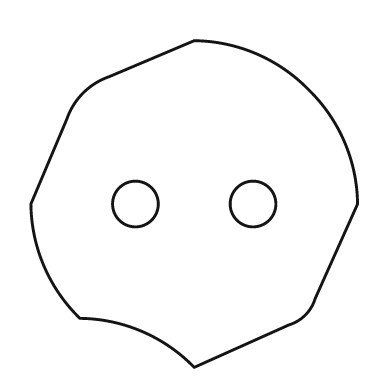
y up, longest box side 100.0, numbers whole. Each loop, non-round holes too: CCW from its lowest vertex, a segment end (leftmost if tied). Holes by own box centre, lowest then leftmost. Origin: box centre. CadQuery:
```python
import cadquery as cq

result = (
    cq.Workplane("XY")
    .moveTo(0.0, -50.0)
    .lineTo(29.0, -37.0)
    .threePointArc((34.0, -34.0), (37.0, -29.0))
    .lineTo(50.0, 0.0)
    .threePointArc((46.0, 19.0), (35.0, 35.0))
    .threePointArc((19.0, 46.0), (0.0, 50.0))
    .lineTo(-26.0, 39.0)
    .threePointArc((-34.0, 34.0), (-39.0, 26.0))
    .lineTo(-50.0, 0.0)
    .threePointArc((-46.0, -19.0), (-35.0, -35.0))
    .threePointArc((-16.0, -39.0), (0.0, -50.0))
    .close()
    .moveTo(-18.0, 0.0)
    .circle(7.0)
    .moveTo(18.0, 0.0)
    .circle(7.0)
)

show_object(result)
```